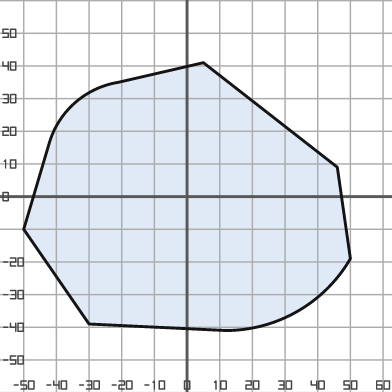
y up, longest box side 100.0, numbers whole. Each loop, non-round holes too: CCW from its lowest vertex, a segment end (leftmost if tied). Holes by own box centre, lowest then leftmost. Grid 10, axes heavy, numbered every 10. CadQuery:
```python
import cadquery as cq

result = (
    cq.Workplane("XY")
    .moveTo(12.0, -41.0)
    .threePointArc((34.0, -35.0), (50.0, -19.0))
    .lineTo(46.0, 9.0)
    .lineTo(5.0, 41.0)
    .lineTo(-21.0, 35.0)
    .threePointArc((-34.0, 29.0), (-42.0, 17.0))
    .lineTo(-50.0, -10.0)
    .lineTo(-30.0, -39.0)
    .close()
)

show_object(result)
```